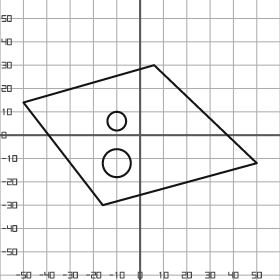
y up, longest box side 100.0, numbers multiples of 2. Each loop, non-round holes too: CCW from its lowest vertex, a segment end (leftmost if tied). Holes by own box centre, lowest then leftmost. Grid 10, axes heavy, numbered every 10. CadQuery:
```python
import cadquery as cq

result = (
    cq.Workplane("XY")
    .moveTo(-16.0, -30.0)
    .lineTo(50.0, -12.0)
    .lineTo(6.0, 30.0)
    .lineTo(-50.0, 14.0)
    .close()
    .moveTo(-10.0, -12.0)
    .circle(6.0)
    .moveTo(-10.0, 6.0)
    .circle(4.0)
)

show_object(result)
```